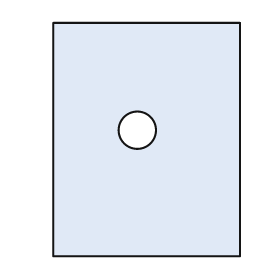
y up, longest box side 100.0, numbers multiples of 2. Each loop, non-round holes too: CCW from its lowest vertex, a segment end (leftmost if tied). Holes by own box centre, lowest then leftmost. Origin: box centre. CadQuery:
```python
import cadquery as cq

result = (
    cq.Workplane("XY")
    .moveTo(-40.0, -50.0)
    .lineTo(40.0, -50.0)
    .lineTo(40.0, 50.0)
    .lineTo(-40.0, 50.0)
    .close()
    .moveTo(-4.0, 4.0)
    .circle(8.0)
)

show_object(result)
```